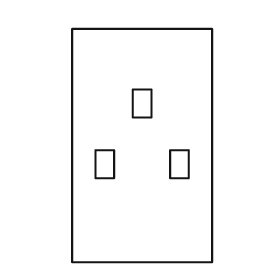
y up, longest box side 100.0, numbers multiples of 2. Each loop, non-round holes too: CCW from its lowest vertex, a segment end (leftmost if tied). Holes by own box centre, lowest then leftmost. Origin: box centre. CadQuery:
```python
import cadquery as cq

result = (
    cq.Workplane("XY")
    .moveTo(-30.0, -50.0)
    .lineTo(30.0, -50.0)
    .lineTo(30.0, 50.0)
    .lineTo(-30.0, 50.0)
    .close()
    .moveTo(-20.0, -14.0)
    .lineTo(-12.0, -14.0)
    .lineTo(-12.0, -2.0)
    .lineTo(-20.0, -2.0)
    .close()
    .moveTo(12.0, -14.0)
    .lineTo(20.0, -14.0)
    .lineTo(20.0, -2.0)
    .lineTo(12.0, -2.0)
    .close()
    .moveTo(-4.0, 12.0)
    .lineTo(4.0, 12.0)
    .lineTo(4.0, 24.0)
    .lineTo(-4.0, 24.0)
    .close()
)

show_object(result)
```